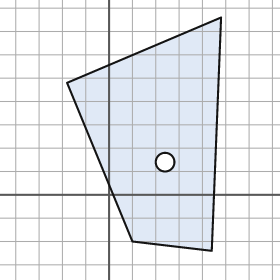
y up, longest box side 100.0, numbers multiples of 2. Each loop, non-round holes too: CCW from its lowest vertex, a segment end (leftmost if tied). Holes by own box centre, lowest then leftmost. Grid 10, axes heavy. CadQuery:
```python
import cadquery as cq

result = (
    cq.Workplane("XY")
    .moveTo(44.0, -24.0)
    .lineTo(48.0, 76.0)
    .lineTo(-18.0, 48.0)
    .lineTo(10.0, -20.0)
    .close()
    .moveTo(24.0, 14.0)
    .circle(4.0)
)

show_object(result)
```